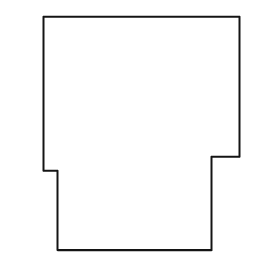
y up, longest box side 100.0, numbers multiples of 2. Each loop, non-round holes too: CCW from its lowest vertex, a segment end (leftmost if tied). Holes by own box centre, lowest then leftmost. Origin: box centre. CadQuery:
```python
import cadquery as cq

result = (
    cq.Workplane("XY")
    .moveTo(-36.0, -50.0)
    .lineTo(30.0, -50.0)
    .lineTo(30.0, -10.0)
    .lineTo(42.0, -10.0)
    .lineTo(42.0, 50.0)
    .lineTo(-42.0, 50.0)
    .lineTo(-42.0, -16.0)
    .lineTo(-36.0, -16.0)
    .close()
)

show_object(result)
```